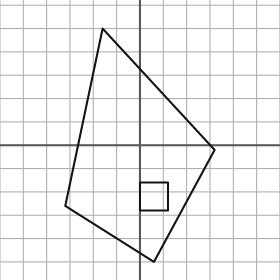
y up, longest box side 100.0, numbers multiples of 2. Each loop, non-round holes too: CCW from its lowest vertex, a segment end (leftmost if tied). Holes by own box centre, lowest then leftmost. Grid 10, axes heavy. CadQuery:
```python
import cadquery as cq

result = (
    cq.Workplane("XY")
    .moveTo(6.0, -50.0)
    .lineTo(32.0, -2.0)
    .lineTo(-16.0, 50.0)
    .lineTo(-32.0, -26.0)
    .close()
    .moveTo(0.0, -28.0)
    .lineTo(12.0, -28.0)
    .lineTo(12.0, -16.0)
    .lineTo(0.0, -16.0)
    .close()
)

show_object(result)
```